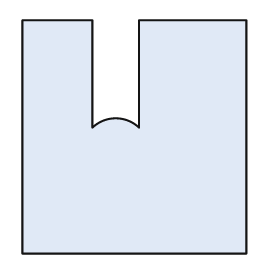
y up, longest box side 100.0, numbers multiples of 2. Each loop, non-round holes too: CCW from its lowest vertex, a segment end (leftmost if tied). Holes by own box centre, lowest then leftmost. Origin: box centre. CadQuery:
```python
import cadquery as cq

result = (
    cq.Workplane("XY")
    .moveTo(-48.0, -50.0)
    .lineTo(48.0, -50.0)
    .lineTo(48.0, 50.0)
    .lineTo(2.0, 50.0)
    .lineTo(2.0, 4.0)
    .threePointArc((-8.0, 8.0), (-18.0, 4.0))
    .lineTo(-18.0, 50.0)
    .lineTo(-48.0, 50.0)
    .close()
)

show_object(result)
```